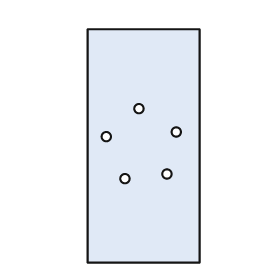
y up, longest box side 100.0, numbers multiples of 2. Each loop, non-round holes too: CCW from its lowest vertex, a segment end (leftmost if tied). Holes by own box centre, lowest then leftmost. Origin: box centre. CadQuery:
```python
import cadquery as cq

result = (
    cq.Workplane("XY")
    .moveTo(-24.0, -50.0)
    .lineTo(24.0, -50.0)
    .lineTo(24.0, 50.0)
    .lineTo(-24.0, 50.0)
    .close()
    .moveTo(-8.0, -14.0)
    .circle(2.0)
    .moveTo(10.0, -12.0)
    .circle(2.0)
    .moveTo(-16.0, 4.0)
    .circle(2.0)
    .moveTo(14.0, 6.0)
    .circle(2.0)
    .moveTo(-2.0, 16.0)
    .circle(2.0)
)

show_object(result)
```